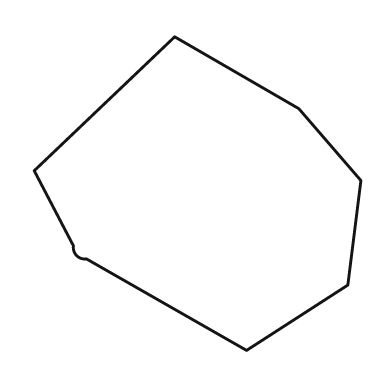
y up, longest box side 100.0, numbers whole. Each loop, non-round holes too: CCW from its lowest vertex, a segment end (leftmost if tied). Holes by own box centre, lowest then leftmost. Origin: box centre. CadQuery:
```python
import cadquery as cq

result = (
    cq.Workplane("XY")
    .moveTo(15.0, -48.0)
    .lineTo(46.0, -28.0)
    .lineTo(50.0, 4.0)
    .lineTo(31.0, 26.0)
    .lineTo(-7.0, 48.0)
    .lineTo(-50.0, 7.0)
    .lineTo(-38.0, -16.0)
    .threePointArc((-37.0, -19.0), (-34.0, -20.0))
    .close()
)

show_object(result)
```